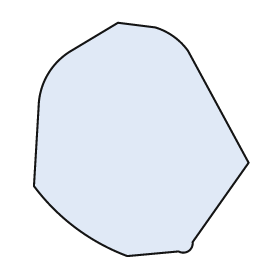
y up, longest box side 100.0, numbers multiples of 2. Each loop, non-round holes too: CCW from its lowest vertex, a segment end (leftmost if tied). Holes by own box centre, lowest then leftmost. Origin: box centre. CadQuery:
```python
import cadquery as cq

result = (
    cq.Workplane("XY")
    .moveTo(-6.0, -50.0)
    .lineTo(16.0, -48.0)
    .threePointArc((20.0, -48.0), (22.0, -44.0))
    .lineTo(46.0, -10.0)
    .lineTo(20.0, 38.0)
    .threePointArc((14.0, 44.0), (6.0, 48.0))
    .lineTo(-10.0, 50.0)
    .lineTo(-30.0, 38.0)
    .threePointArc((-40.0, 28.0), (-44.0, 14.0))
    .lineTo(-46.0, -20.0)
    .threePointArc((-28.0, -38.0), (-6.0, -50.0))
    .close()
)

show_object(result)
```